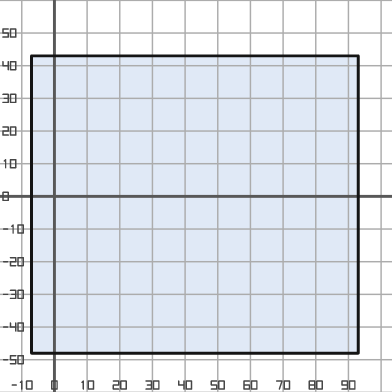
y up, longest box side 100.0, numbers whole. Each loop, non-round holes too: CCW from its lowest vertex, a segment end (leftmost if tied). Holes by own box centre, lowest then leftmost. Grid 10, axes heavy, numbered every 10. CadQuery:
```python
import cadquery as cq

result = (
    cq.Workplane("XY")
    .moveTo(-7.0, -48.0)
    .lineTo(93.0, -48.0)
    .lineTo(93.0, 43.0)
    .lineTo(-7.0, 43.0)
    .close()
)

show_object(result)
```